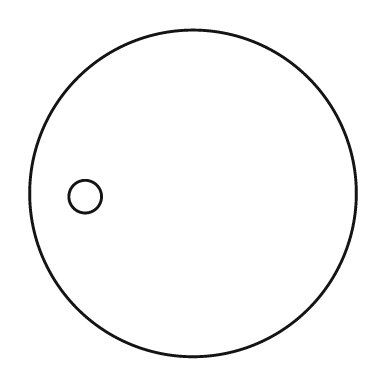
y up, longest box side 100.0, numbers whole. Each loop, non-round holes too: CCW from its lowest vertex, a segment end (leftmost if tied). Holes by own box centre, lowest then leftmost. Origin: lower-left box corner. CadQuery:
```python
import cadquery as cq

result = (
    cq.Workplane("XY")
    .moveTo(50.0, 50.0)
    .circle(50.0)
    .moveTo(17.0, 49.0)
    .circle(5.0)
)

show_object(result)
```